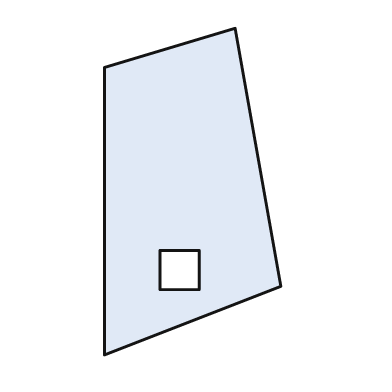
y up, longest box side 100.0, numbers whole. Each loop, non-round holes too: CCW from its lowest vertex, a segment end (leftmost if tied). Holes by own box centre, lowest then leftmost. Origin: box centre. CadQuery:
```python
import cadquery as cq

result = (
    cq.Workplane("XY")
    .moveTo(-27.0, -50.0)
    .lineTo(27.0, -29.0)
    .lineTo(13.0, 50.0)
    .lineTo(-27.0, 38.0)
    .close()
    .moveTo(-10.0, -30.0)
    .lineTo(2.0, -30.0)
    .lineTo(2.0, -18.0)
    .lineTo(-10.0, -18.0)
    .close()
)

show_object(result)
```